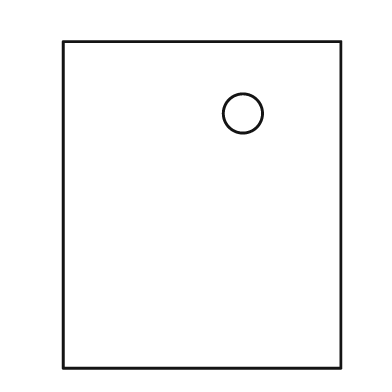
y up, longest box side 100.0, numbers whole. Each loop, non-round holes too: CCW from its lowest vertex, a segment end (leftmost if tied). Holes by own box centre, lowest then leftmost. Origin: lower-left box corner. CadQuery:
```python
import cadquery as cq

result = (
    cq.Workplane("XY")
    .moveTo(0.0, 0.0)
    .lineTo(85.0, 0.0)
    .lineTo(85.0, 100.0)
    .lineTo(0.0, 100.0)
    .close()
    .moveTo(55.0, 78.0)
    .circle(6.0)
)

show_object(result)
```